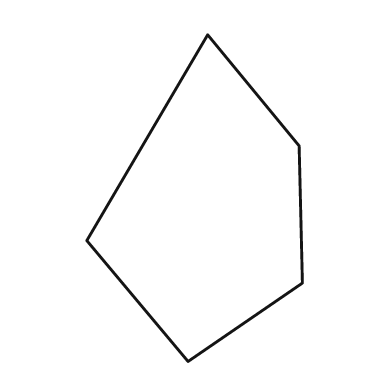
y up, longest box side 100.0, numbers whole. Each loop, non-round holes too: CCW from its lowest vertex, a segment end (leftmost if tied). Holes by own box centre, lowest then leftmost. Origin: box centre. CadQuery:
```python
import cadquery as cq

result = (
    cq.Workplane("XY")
    .moveTo(-2.0, -50.0)
    .lineTo(33.0, -26.0)
    .lineTo(32.0, 16.0)
    .lineTo(4.0, 50.0)
    .lineTo(-33.0, -13.0)
    .close()
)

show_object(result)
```